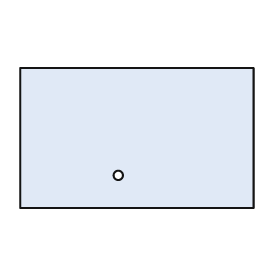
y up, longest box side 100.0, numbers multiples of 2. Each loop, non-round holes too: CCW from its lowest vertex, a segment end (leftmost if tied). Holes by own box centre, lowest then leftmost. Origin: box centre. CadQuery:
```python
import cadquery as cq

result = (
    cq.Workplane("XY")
    .moveTo(-50.0, -30.0)
    .lineTo(50.0, -30.0)
    .lineTo(50.0, 30.0)
    .lineTo(-50.0, 30.0)
    .close()
    .moveTo(-8.0, -16.0)
    .circle(2.0)
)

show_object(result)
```